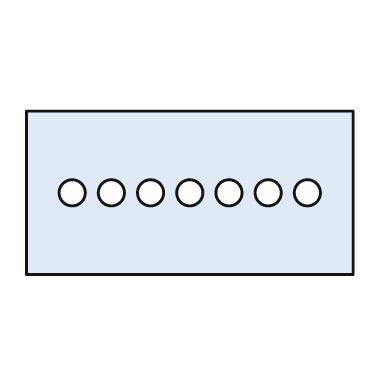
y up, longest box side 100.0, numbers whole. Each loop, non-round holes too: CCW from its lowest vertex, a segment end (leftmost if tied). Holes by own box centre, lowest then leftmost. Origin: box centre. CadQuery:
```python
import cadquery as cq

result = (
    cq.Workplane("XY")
    .moveTo(-50.0, -25.0)
    .lineTo(50.0, -25.0)
    .lineTo(50.0, 25.0)
    .lineTo(-50.0, 25.0)
    .close()
    .moveTo(-36.0, 0.0)
    .circle(4.0)
    .moveTo(-24.0, 0.0)
    .circle(4.0)
    .moveTo(-12.0, 0.0)
    .circle(4.0)
    .moveTo(0.0, 0.0)
    .circle(4.0)
    .moveTo(12.0, 0.0)
    .circle(4.0)
    .moveTo(24.0, 0.0)
    .circle(4.0)
    .moveTo(36.0, 0.0)
    .circle(4.0)
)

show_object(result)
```